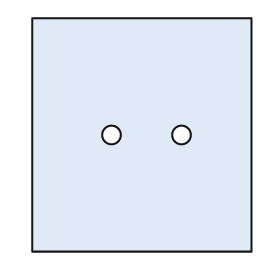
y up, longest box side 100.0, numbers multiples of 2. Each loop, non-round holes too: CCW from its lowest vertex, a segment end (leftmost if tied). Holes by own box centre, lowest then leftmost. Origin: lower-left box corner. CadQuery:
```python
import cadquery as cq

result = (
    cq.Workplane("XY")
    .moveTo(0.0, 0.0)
    .lineTo(94.0, 0.0)
    .lineTo(94.0, 100.0)
    .lineTo(0.0, 100.0)
    .close()
    .moveTo(34.0, 50.0)
    .circle(4.0)
    .moveTo(64.0, 50.0)
    .circle(4.0)
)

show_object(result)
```